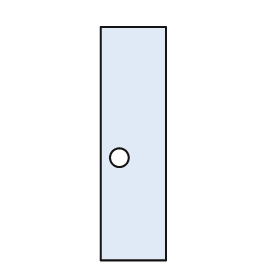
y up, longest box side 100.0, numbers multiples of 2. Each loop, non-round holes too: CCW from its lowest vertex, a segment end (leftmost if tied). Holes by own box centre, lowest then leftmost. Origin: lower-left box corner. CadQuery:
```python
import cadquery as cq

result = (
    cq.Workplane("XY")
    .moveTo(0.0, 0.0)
    .lineTo(28.0, 0.0)
    .lineTo(28.0, 100.0)
    .lineTo(0.0, 100.0)
    .close()
    .moveTo(8.0, 44.0)
    .circle(4.0)
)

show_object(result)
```